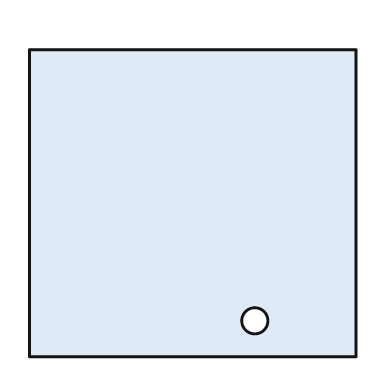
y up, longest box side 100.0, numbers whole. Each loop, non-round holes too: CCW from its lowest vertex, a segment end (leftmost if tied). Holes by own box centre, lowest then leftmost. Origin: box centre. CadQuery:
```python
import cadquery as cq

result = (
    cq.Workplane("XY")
    .moveTo(-50.0, -47.0)
    .lineTo(50.0, -47.0)
    .lineTo(50.0, 47.0)
    .lineTo(-50.0, 47.0)
    .close()
    .moveTo(19.0, -36.0)
    .circle(4.0)
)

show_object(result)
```